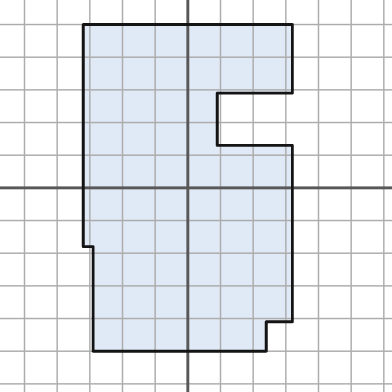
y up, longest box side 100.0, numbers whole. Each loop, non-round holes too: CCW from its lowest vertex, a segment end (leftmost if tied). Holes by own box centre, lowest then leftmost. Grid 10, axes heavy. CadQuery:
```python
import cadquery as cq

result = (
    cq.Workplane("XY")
    .moveTo(-29.0, -50.0)
    .lineTo(24.0, -50.0)
    .lineTo(24.0, -41.0)
    .lineTo(32.0, -41.0)
    .lineTo(32.0, 13.0)
    .lineTo(9.0, 13.0)
    .lineTo(9.0, 29.0)
    .lineTo(32.0, 29.0)
    .lineTo(32.0, 50.0)
    .lineTo(-32.0, 50.0)
    .lineTo(-32.0, -18.0)
    .lineTo(-29.0, -18.0)
    .close()
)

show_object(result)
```